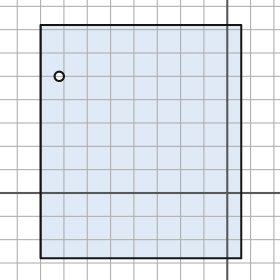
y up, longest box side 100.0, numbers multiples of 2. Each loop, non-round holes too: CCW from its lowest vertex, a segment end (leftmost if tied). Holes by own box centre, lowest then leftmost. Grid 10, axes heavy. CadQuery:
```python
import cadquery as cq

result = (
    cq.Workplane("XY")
    .moveTo(-80.0, -28.0)
    .lineTo(6.0, -28.0)
    .lineTo(6.0, 72.0)
    .lineTo(-80.0, 72.0)
    .close()
    .moveTo(-72.0, 50.0)
    .circle(2.0)
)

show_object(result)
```